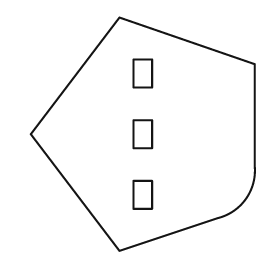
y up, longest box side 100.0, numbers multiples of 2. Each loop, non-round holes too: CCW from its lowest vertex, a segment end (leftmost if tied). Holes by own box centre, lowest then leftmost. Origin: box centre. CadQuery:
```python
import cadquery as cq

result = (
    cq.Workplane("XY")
    .moveTo(-10.0, -50.0)
    .lineTo(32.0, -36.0)
    .threePointArc((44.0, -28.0), (48.0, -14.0))
    .lineTo(48.0, 30.0)
    .lineTo(-10.0, 50.0)
    .lineTo(-48.0, 0.0)
    .close()
    .moveTo(-4.0, -32.0)
    .lineTo(4.0, -32.0)
    .lineTo(4.0, -20.0)
    .lineTo(-4.0, -20.0)
    .close()
    .moveTo(-4.0, -6.0)
    .lineTo(4.0, -6.0)
    .lineTo(4.0, 6.0)
    .lineTo(-4.0, 6.0)
    .close()
    .moveTo(-4.0, 20.0)
    .lineTo(4.0, 20.0)
    .lineTo(4.0, 32.0)
    .lineTo(-4.0, 32.0)
    .close()
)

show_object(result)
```